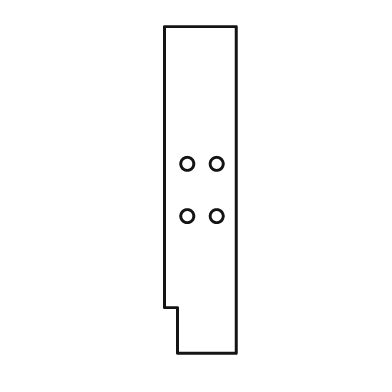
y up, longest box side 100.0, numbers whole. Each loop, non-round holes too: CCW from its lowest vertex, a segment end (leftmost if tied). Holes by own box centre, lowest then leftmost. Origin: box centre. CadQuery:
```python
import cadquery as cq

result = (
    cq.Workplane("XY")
    .moveTo(-7.0, -50.0)
    .lineTo(11.0, -50.0)
    .lineTo(11.0, 50.0)
    .lineTo(-11.0, 50.0)
    .lineTo(-11.0, -36.0)
    .lineTo(-7.0, -36.0)
    .close()
    .moveTo(-4.0, -8.0)
    .circle(2.0)
    .moveTo(5.0, -8.0)
    .circle(2.0)
    .moveTo(-4.0, 8.0)
    .circle(2.0)
    .moveTo(5.0, 8.0)
    .circle(2.0)
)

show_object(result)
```